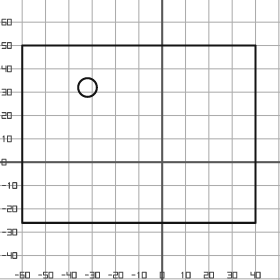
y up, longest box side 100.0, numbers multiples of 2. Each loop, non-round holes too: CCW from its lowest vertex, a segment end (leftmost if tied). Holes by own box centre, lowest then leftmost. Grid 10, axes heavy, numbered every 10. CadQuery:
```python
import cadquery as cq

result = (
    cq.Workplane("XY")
    .moveTo(-60.0, -26.0)
    .lineTo(40.0, -26.0)
    .lineTo(40.0, 50.0)
    .lineTo(-60.0, 50.0)
    .close()
    .moveTo(-32.0, 32.0)
    .circle(4.0)
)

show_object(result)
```